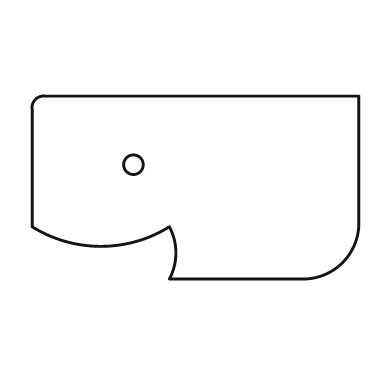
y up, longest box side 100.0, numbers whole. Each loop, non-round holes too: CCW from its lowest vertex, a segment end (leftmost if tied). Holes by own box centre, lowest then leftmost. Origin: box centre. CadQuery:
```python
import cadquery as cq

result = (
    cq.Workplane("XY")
    .moveTo(-8.0, -28.0)
    .lineTo(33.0, -28.0)
    .threePointArc((45.0, -23.0), (50.0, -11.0))
    .lineTo(50.0, 28.0)
    .lineTo(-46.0, 28.0)
    .threePointArc((-49.0, 27.0), (-50.0, 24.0))
    .lineTo(-50.0, -12.0)
    .threePointArc((-29.0, -18.0), (-8.0, -12.0))
    .threePointArc((-6.0, -20.0), (-8.0, -28.0))
    .close()
    .moveTo(-19.0, 7.0)
    .circle(3.0)
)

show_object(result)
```